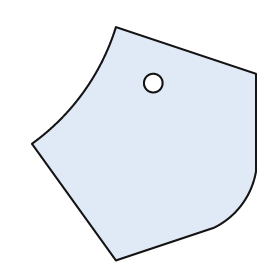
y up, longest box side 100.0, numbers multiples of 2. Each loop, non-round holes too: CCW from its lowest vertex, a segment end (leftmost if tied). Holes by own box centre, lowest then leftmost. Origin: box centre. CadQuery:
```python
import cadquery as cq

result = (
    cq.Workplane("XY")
    .moveTo(-12.0, -50.0)
    .lineTo(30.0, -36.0)
    .threePointArc((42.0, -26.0), (48.0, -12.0))
    .lineTo(48.0, 30.0)
    .lineTo(-12.0, 50.0)
    .threePointArc((-26.0, 22.0), (-48.0, 0.0))
    .close()
    .moveTo(4.0, 26.0)
    .circle(4.0)
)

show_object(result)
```